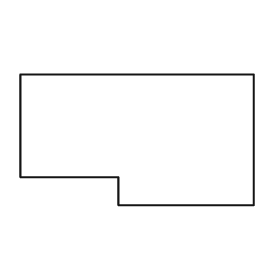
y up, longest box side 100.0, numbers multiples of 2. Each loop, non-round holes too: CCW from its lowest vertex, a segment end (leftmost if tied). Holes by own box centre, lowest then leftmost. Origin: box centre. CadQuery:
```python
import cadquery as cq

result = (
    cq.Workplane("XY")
    .moveTo(-8.0, -28.0)
    .lineTo(50.0, -28.0)
    .lineTo(50.0, 28.0)
    .lineTo(-50.0, 28.0)
    .lineTo(-50.0, -16.0)
    .lineTo(-8.0, -16.0)
    .close()
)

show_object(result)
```